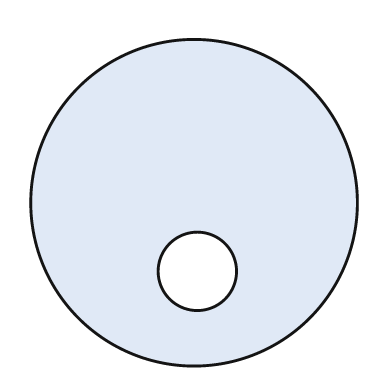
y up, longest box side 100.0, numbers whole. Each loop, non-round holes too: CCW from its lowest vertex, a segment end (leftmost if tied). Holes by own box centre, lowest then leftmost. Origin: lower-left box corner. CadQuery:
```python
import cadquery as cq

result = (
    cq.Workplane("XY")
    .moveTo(50.0, 50.0)
    .circle(50.0)
    .moveTo(51.0, 29.0)
    .circle(12.0)
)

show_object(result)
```